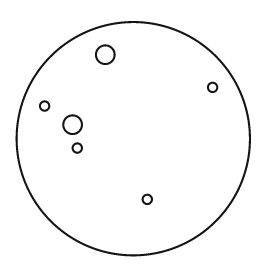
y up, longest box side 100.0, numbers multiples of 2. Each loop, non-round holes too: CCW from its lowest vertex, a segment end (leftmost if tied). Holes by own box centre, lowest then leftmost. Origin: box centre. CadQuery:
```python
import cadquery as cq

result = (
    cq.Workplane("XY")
    .moveTo(0.0, 0.0)
    .circle(50.0)
    .moveTo(6.0, -26.0)
    .circle(2.0)
    .moveTo(-24.0, -4.0)
    .circle(2.0)
    .moveTo(-26.0, 6.0)
    .circle(4.0)
    .moveTo(-38.0, 14.0)
    .circle(2.0)
    .moveTo(34.0, 22.0)
    .circle(2.0)
    .moveTo(-12.0, 36.0)
    .circle(4.0)
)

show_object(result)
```